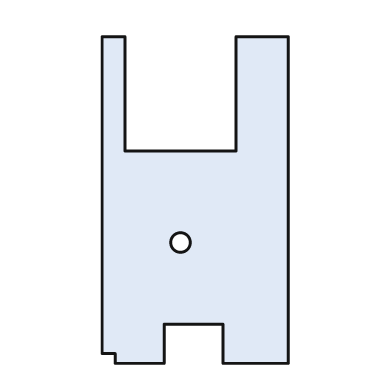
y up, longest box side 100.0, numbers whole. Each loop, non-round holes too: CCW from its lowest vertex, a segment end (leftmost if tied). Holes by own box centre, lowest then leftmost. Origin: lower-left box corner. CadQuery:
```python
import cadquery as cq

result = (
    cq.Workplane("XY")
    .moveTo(4.0, 0.0)
    .lineTo(19.0, 0.0)
    .lineTo(19.0, 12.0)
    .lineTo(37.0, 12.0)
    .lineTo(37.0, 0.0)
    .lineTo(57.0, 0.0)
    .lineTo(57.0, 100.0)
    .lineTo(41.0, 100.0)
    .lineTo(41.0, 65.0)
    .lineTo(7.0, 65.0)
    .lineTo(7.0, 100.0)
    .lineTo(0.0, 100.0)
    .lineTo(0.0, 3.0)
    .lineTo(4.0, 3.0)
    .close()
    .moveTo(24.0, 37.0)
    .circle(3.0)
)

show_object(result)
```